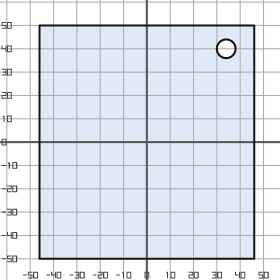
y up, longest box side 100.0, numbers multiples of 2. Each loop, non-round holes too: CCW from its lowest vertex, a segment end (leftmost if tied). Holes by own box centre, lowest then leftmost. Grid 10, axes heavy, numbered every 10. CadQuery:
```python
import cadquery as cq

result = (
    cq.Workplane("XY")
    .moveTo(-46.0, -50.0)
    .lineTo(46.0, -50.0)
    .lineTo(46.0, 50.0)
    .lineTo(-46.0, 50.0)
    .close()
    .moveTo(34.0, 40.0)
    .circle(4.0)
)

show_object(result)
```